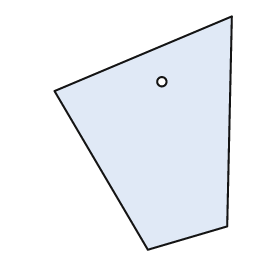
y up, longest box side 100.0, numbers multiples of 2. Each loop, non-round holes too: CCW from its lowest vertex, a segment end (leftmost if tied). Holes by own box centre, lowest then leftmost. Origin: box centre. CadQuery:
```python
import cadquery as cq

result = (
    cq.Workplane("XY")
    .moveTo(2.0, -50.0)
    .lineTo(36.0, -40.0)
    .lineTo(38.0, 50.0)
    .lineTo(-38.0, 18.0)
    .close()
    .moveTo(8.0, 22.0)
    .circle(2.0)
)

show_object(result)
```